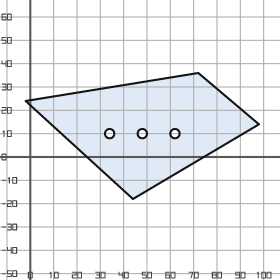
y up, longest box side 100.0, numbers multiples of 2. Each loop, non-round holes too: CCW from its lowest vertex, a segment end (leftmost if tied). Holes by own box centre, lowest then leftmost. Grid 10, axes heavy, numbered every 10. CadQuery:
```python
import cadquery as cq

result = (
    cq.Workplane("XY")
    .moveTo(44.0, -18.0)
    .lineTo(98.0, 14.0)
    .lineTo(72.0, 36.0)
    .lineTo(-2.0, 24.0)
    .close()
    .moveTo(34.0, 10.0)
    .circle(2.0)
    .moveTo(48.0, 10.0)
    .circle(2.0)
    .moveTo(62.0, 10.0)
    .circle(2.0)
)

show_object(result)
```